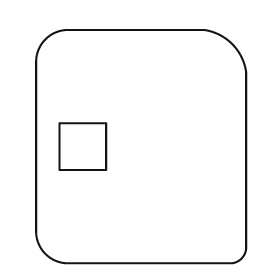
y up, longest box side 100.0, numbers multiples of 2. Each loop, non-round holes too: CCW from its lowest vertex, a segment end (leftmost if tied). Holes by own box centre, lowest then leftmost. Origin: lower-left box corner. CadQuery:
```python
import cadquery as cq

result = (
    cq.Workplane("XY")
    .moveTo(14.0, 0.0)
    .lineTo(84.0, 0.0)
    .threePointArc((88.0, 2.0), (90.0, 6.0))
    .lineTo(90.0, 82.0)
    .threePointArc((84.0, 94.0), (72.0, 100.0))
    .lineTo(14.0, 100.0)
    .threePointArc((4.0, 96.0), (0.0, 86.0))
    .lineTo(0.0, 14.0)
    .threePointArc((4.0, 4.0), (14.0, 0.0))
    .close()
    .moveTo(10.0, 40.0)
    .lineTo(30.0, 40.0)
    .lineTo(30.0, 60.0)
    .lineTo(10.0, 60.0)
    .close()
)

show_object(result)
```